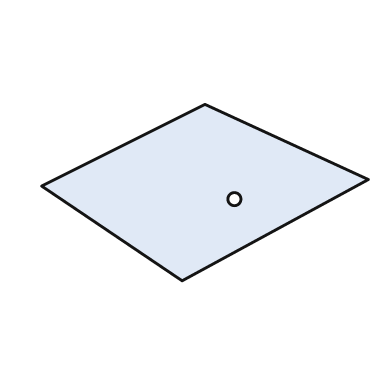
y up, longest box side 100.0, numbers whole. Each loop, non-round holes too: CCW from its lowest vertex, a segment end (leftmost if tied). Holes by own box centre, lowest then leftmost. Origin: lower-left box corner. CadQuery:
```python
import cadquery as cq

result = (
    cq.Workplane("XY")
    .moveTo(43.0, 0.0)
    .lineTo(100.0, 31.0)
    .lineTo(50.0, 54.0)
    .lineTo(0.0, 29.0)
    .close()
    .moveTo(59.0, 25.0)
    .circle(2.0)
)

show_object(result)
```